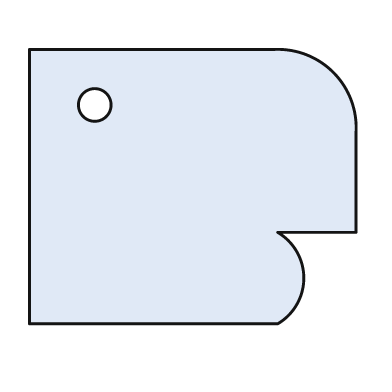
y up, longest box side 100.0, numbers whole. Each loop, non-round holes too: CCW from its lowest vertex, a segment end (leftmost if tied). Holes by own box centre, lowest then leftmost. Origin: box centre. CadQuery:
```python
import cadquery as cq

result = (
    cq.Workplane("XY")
    .moveTo(-50.0, -42.0)
    .lineTo(26.0, -42.0)
    .threePointArc((34.0, -28.0), (26.0, -14.0))
    .lineTo(50.0, -14.0)
    .lineTo(50.0, 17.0)
    .threePointArc((43.0, 35.0), (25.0, 42.0))
    .lineTo(-50.0, 42.0)
    .close()
    .moveTo(-30.0, 25.0)
    .circle(5.0)
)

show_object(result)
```